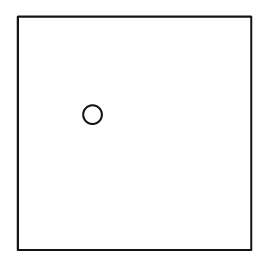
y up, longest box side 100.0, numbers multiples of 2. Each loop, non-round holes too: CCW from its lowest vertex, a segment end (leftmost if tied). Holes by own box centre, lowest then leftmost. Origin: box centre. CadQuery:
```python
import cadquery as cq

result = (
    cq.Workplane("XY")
    .moveTo(-50.0, -50.0)
    .lineTo(50.0, -50.0)
    .lineTo(50.0, 50.0)
    .lineTo(-50.0, 50.0)
    .close()
    .moveTo(-18.0, 8.0)
    .circle(4.0)
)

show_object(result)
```